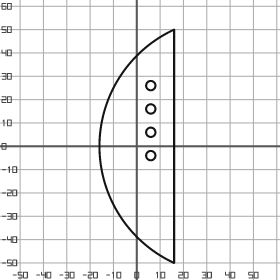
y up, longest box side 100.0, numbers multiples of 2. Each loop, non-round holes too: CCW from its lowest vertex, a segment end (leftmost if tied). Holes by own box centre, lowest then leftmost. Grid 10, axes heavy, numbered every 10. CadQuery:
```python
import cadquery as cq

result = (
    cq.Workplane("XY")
    .moveTo(16.0, -50.0)
    .lineTo(16.0, 50.0)
    .threePointArc((-16.0, 0.0), (16.0, -50.0))
    .close()
    .moveTo(6.0, -4.0)
    .circle(2.0)
    .moveTo(6.0, 6.0)
    .circle(2.0)
    .moveTo(6.0, 16.0)
    .circle(2.0)
    .moveTo(6.0, 26.0)
    .circle(2.0)
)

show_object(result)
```